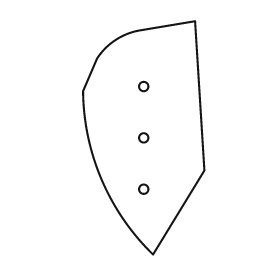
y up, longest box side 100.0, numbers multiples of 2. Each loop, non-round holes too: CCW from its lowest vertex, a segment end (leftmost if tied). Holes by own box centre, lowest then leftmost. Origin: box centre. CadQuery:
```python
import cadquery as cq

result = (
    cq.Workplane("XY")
    .moveTo(4.0, -50.0)
    .lineTo(26.0, -14.0)
    .lineTo(22.0, 50.0)
    .lineTo(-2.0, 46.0)
    .threePointArc((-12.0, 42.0), (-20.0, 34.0))
    .lineTo(-26.0, 20.0)
    .threePointArc((-18.0, -18.0), (4.0, -50.0))
    .close()
    .moveTo(0.0, -22.0)
    .circle(2.0)
    .moveTo(0.0, 0.0)
    .circle(2.0)
    .moveTo(0.0, 22.0)
    .circle(2.0)
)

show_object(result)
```